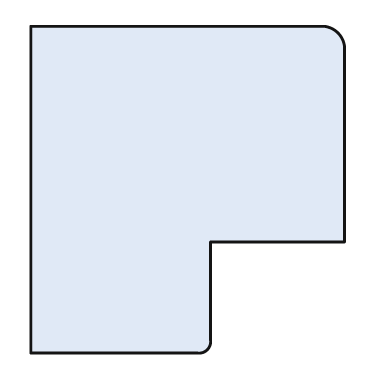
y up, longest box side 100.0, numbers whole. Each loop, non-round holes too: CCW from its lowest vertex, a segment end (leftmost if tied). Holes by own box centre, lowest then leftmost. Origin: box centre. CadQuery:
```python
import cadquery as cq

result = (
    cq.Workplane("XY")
    .moveTo(-48.0, -50.0)
    .lineTo(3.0, -50.0)
    .threePointArc((6.0, -49.0), (7.0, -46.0))
    .lineTo(7.0, -16.0)
    .lineTo(48.0, -16.0)
    .lineTo(48.0, 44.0)
    .threePointArc((46.0, 48.0), (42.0, 50.0))
    .lineTo(-48.0, 50.0)
    .close()
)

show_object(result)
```